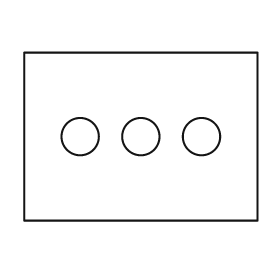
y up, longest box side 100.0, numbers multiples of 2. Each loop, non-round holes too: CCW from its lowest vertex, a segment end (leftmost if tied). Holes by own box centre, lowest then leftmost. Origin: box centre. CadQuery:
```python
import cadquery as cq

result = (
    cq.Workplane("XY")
    .moveTo(-50.0, -36.0)
    .lineTo(50.0, -36.0)
    .lineTo(50.0, 36.0)
    .lineTo(-50.0, 36.0)
    .close()
    .moveTo(-26.0, 0.0)
    .circle(8.0)
    .moveTo(0.0, 0.0)
    .circle(8.0)
    .moveTo(26.0, 0.0)
    .circle(8.0)
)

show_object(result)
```